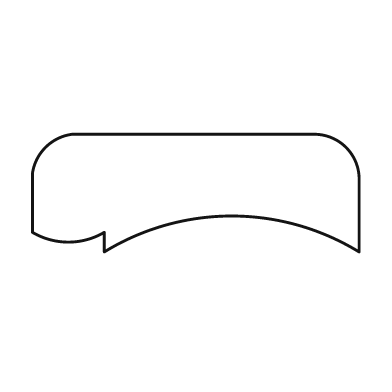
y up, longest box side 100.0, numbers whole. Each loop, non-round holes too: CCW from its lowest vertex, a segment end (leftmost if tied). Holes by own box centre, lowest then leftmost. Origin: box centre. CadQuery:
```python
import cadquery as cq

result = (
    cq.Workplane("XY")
    .moveTo(-28.0, -18.0)
    .threePointArc((11.0, -7.0), (50.0, -18.0))
    .lineTo(50.0, 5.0)
    .threePointArc((46.0, 14.0), (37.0, 18.0))
    .lineTo(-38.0, 18.0)
    .threePointArc((-46.0, 14.0), (-50.0, 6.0))
    .lineTo(-50.0, -12.0)
    .threePointArc((-39.0, -15.0), (-28.0, -12.0))
    .close()
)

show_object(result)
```